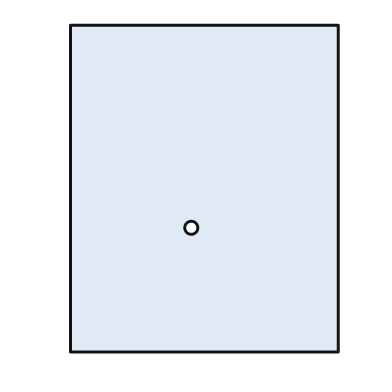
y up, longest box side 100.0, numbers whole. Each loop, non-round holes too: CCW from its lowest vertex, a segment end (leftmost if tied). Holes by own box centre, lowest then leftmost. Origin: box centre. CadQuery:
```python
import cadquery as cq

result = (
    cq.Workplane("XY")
    .moveTo(-41.0, -50.0)
    .lineTo(41.0, -50.0)
    .lineTo(41.0, 50.0)
    .lineTo(-41.0, 50.0)
    .close()
    .moveTo(-4.0, -12.0)
    .circle(2.0)
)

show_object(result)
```